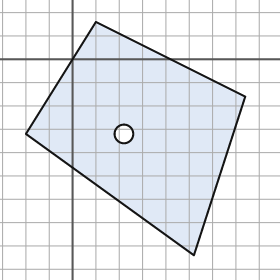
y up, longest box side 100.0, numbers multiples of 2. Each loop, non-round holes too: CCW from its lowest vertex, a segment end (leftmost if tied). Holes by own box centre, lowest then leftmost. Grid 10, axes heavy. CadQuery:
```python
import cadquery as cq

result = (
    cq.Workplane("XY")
    .moveTo(52.0, -84.0)
    .lineTo(74.0, -16.0)
    .lineTo(10.0, 16.0)
    .lineTo(-20.0, -32.0)
    .close()
    .moveTo(22.0, -32.0)
    .circle(4.0)
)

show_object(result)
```